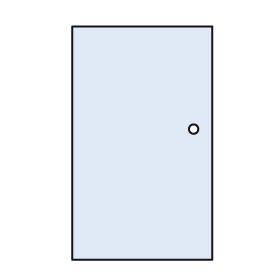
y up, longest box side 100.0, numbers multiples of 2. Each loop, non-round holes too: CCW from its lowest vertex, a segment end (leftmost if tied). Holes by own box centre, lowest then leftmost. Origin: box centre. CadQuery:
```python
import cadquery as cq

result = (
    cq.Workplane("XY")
    .moveTo(-30.0, -50.0)
    .lineTo(30.0, -50.0)
    .lineTo(30.0, 50.0)
    .lineTo(-30.0, 50.0)
    .close()
    .moveTo(22.0, 6.0)
    .circle(2.0)
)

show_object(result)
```